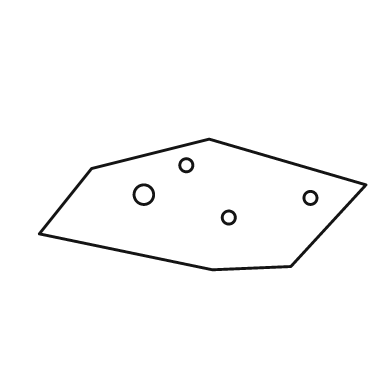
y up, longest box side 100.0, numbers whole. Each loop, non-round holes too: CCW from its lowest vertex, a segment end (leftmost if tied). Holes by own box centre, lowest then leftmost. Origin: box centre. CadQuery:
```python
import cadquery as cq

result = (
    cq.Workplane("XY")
    .moveTo(3.0, -20.0)
    .lineTo(27.0, -19.0)
    .lineTo(50.0, 6.0)
    .lineTo(2.0, 20.0)
    .lineTo(-34.0, 11.0)
    .lineTo(-50.0, -9.0)
    .close()
    .moveTo(8.0, -4.0)
    .circle(2.0)
    .moveTo(33.0, 2.0)
    .circle(2.0)
    .moveTo(-18.0, 3.0)
    .circle(3.0)
    .moveTo(-5.0, 12.0)
    .circle(2.0)
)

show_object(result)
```